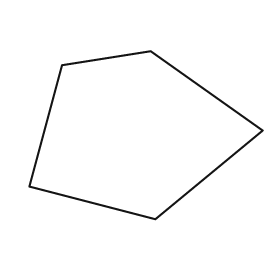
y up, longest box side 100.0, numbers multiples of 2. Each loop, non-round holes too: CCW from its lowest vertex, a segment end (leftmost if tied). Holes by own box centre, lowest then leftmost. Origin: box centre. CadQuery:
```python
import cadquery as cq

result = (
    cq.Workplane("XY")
    .moveTo(4.0, -36.0)
    .lineTo(50.0, 2.0)
    .lineTo(2.0, 36.0)
    .lineTo(-36.0, 30.0)
    .lineTo(-50.0, -22.0)
    .close()
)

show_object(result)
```